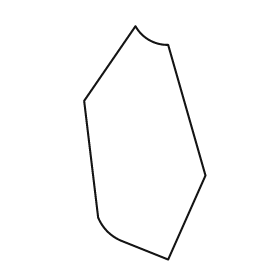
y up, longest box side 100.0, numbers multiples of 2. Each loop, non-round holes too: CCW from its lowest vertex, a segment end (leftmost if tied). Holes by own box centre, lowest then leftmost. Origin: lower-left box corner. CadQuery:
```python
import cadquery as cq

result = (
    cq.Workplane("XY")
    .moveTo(36.0, 0.0)
    .lineTo(52.0, 36.0)
    .lineTo(36.0, 92.0)
    .threePointArc((28.0, 94.0), (22.0, 100.0))
    .lineTo(0.0, 68.0)
    .lineTo(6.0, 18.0)
    .threePointArc((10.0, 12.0), (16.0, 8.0))
    .close()
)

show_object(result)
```